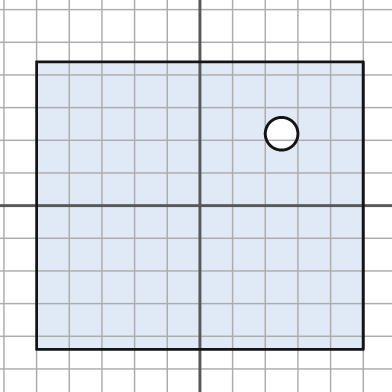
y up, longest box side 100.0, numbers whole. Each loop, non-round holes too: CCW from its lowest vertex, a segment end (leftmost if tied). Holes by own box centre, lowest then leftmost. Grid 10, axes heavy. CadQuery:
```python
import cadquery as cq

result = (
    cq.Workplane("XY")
    .moveTo(-50.0, -44.0)
    .lineTo(50.0, -44.0)
    .lineTo(50.0, 44.0)
    .lineTo(-50.0, 44.0)
    .close()
    .moveTo(25.0, 22.0)
    .circle(5.0)
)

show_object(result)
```